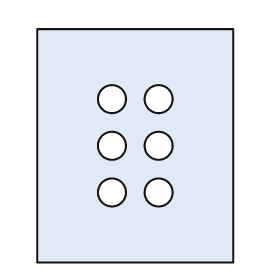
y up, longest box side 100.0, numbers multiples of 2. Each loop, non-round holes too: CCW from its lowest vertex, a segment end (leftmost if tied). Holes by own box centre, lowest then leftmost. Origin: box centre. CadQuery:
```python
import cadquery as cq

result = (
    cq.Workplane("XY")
    .moveTo(-42.0, -50.0)
    .lineTo(42.0, -50.0)
    .lineTo(42.0, 50.0)
    .lineTo(-42.0, 50.0)
    .close()
    .moveTo(-10.0, -20.0)
    .circle(6.0)
    .moveTo(10.0, -20.0)
    .circle(6.0)
    .moveTo(-10.0, 0.0)
    .circle(6.0)
    .moveTo(10.0, 0.0)
    .circle(6.0)
    .moveTo(-10.0, 20.0)
    .circle(6.0)
    .moveTo(10.0, 20.0)
    .circle(6.0)
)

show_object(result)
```